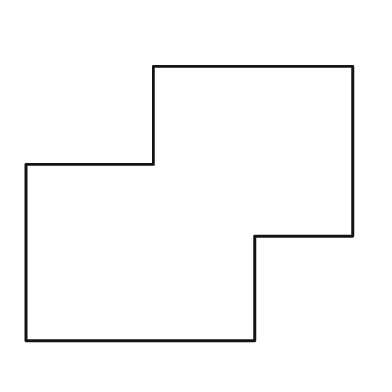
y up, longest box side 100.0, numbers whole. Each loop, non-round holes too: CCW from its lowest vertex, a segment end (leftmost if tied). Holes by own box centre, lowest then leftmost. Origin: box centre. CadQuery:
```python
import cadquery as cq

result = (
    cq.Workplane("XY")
    .moveTo(-50.0, -42.0)
    .lineTo(20.0, -42.0)
    .lineTo(20.0, -10.0)
    .lineTo(50.0, -10.0)
    .lineTo(50.0, 42.0)
    .lineTo(-11.0, 42.0)
    .lineTo(-11.0, 12.0)
    .lineTo(-50.0, 12.0)
    .close()
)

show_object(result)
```